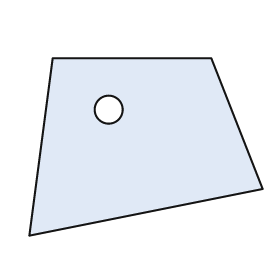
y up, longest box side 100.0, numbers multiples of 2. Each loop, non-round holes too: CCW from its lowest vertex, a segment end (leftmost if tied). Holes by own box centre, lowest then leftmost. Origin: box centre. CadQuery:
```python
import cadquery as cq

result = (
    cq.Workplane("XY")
    .moveTo(-50.0, -38.0)
    .lineTo(50.0, -18.0)
    .lineTo(28.0, 38.0)
    .lineTo(-40.0, 38.0)
    .close()
    .moveTo(-16.0, 16.0)
    .circle(6.0)
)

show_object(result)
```